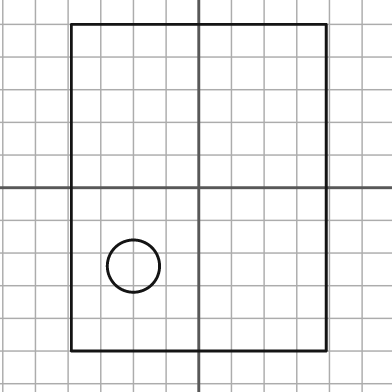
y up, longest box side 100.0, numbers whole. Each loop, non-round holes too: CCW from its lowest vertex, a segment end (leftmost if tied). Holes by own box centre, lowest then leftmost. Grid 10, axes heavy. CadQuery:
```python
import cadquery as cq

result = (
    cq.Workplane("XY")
    .moveTo(-39.0, -50.0)
    .lineTo(39.0, -50.0)
    .lineTo(39.0, 50.0)
    .lineTo(-39.0, 50.0)
    .close()
    .moveTo(-20.0, -24.0)
    .circle(8.0)
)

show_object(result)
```